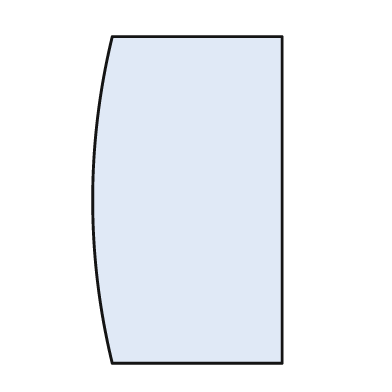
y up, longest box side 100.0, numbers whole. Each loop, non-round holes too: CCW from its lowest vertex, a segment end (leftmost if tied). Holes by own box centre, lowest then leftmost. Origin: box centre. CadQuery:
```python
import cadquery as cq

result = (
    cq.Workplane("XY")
    .moveTo(-23.0, -50.0)
    .lineTo(29.0, -50.0)
    .lineTo(29.0, 50.0)
    .lineTo(-23.0, 50.0)
    .threePointArc((-29.0, 0.0), (-23.0, -50.0))
    .close()
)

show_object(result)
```